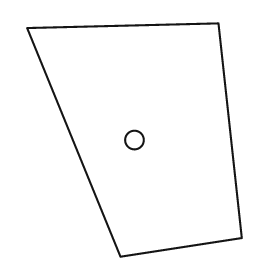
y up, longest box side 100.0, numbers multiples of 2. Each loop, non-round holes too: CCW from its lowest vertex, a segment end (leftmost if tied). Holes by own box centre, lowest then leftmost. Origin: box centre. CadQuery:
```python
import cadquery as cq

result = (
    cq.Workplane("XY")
    .moveTo(-6.0, -50.0)
    .lineTo(46.0, -42.0)
    .lineTo(36.0, 50.0)
    .lineTo(-46.0, 48.0)
    .close()
    .moveTo(0.0, 0.0)
    .circle(4.0)
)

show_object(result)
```